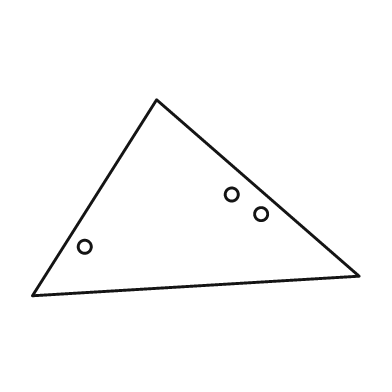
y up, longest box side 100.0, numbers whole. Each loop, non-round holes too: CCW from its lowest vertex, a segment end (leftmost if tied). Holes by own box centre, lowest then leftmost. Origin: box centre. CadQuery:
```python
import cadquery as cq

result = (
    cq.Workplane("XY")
    .moveTo(-50.0, -30.0)
    .lineTo(50.0, -24.0)
    .lineTo(-12.0, 30.0)
    .close()
    .moveTo(-34.0, -15.0)
    .circle(2.0)
    .moveTo(20.0, -5.0)
    .circle(2.0)
    .moveTo(11.0, 1.0)
    .circle(2.0)
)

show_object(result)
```